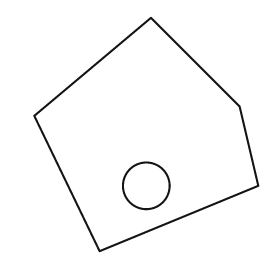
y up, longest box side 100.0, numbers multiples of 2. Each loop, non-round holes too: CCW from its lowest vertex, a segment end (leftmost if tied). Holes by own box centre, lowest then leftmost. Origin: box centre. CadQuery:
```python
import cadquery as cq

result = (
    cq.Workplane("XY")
    .moveTo(-20.0, -50.0)
    .lineTo(48.0, -22.0)
    .lineTo(40.0, 12.0)
    .lineTo(2.0, 50.0)
    .lineTo(-48.0, 8.0)
    .close()
    .moveTo(0.0, -22.0)
    .circle(10.0)
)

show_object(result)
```